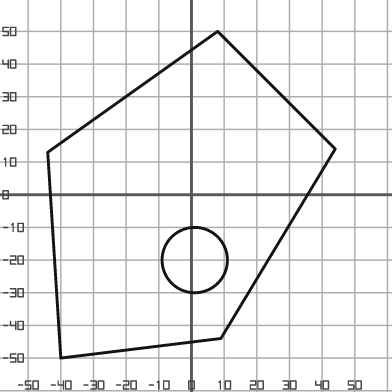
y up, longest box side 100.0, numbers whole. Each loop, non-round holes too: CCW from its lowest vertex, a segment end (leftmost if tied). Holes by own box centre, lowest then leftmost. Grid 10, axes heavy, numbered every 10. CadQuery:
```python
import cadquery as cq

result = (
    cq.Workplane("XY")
    .moveTo(-40.0, -50.0)
    .lineTo(9.0, -44.0)
    .lineTo(44.0, 14.0)
    .lineTo(8.0, 50.0)
    .lineTo(-44.0, 13.0)
    .close()
    .moveTo(1.0, -20.0)
    .circle(10.0)
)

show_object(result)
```